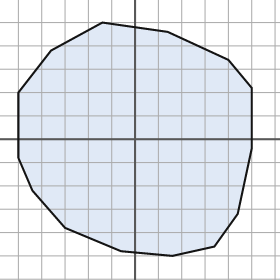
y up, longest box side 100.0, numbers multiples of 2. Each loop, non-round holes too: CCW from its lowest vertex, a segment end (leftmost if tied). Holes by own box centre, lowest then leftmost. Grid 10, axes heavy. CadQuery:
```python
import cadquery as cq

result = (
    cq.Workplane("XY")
    .moveTo(16.0, -50.0)
    .lineTo(34.0, -46.0)
    .lineTo(44.0, -32.0)
    .lineTo(50.0, -4.0)
    .lineTo(50.0, 22.0)
    .lineTo(40.0, 34.0)
    .lineTo(14.0, 46.0)
    .lineTo(-14.0, 50.0)
    .lineTo(-36.0, 38.0)
    .lineTo(-50.0, 20.0)
    .lineTo(-50.0, -8.0)
    .lineTo(-44.0, -22.0)
    .lineTo(-30.0, -38.0)
    .lineTo(-6.0, -48.0)
    .close()
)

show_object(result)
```